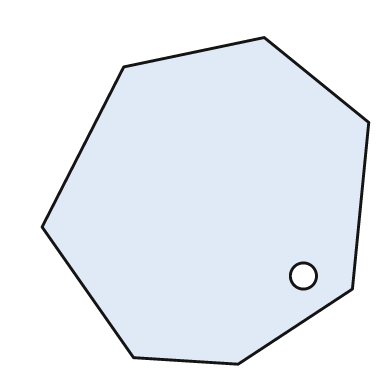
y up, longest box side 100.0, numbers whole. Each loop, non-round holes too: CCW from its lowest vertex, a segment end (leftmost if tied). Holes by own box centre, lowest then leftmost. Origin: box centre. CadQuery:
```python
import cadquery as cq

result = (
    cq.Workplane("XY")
    .moveTo(10.0, -50.0)
    .lineTo(45.0, -27.0)
    .lineTo(50.0, 24.0)
    .lineTo(18.0, 50.0)
    .lineTo(-25.0, 41.0)
    .lineTo(-50.0, -8.0)
    .lineTo(-22.0, -48.0)
    .close()
    .moveTo(30.0, -23.0)
    .circle(4.0)
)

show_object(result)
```